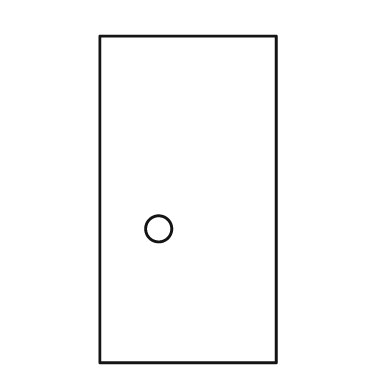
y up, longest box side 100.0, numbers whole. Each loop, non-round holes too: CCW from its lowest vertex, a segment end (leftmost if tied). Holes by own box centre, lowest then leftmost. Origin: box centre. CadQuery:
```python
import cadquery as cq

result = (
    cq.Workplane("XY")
    .moveTo(-27.0, -50.0)
    .lineTo(27.0, -50.0)
    .lineTo(27.0, 50.0)
    .lineTo(-27.0, 50.0)
    .close()
    .moveTo(-9.0, -9.0)
    .circle(4.0)
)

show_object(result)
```